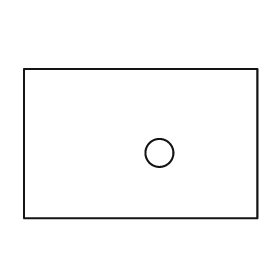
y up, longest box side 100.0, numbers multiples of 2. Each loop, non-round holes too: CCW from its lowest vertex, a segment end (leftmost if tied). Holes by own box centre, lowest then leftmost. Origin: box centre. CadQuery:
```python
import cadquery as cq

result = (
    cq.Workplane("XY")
    .moveTo(-50.0, -32.0)
    .lineTo(50.0, -32.0)
    .lineTo(50.0, 32.0)
    .lineTo(-50.0, 32.0)
    .close()
    .moveTo(8.0, -4.0)
    .circle(6.0)
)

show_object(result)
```